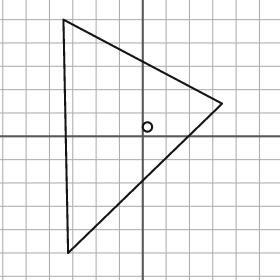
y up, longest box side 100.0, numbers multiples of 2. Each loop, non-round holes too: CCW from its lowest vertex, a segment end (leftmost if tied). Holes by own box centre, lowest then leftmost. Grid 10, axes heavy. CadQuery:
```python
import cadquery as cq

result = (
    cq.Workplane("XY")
    .moveTo(-32.0, -50.0)
    .lineTo(34.0, 14.0)
    .lineTo(-34.0, 50.0)
    .close()
    .moveTo(2.0, 4.0)
    .circle(2.0)
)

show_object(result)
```